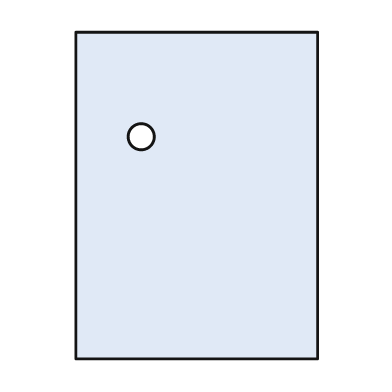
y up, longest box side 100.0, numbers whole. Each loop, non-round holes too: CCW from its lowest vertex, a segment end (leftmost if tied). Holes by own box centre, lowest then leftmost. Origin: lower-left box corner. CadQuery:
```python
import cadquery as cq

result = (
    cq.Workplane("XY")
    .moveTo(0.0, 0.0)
    .lineTo(74.0, 0.0)
    .lineTo(74.0, 100.0)
    .lineTo(0.0, 100.0)
    .close()
    .moveTo(20.0, 68.0)
    .circle(4.0)
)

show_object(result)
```